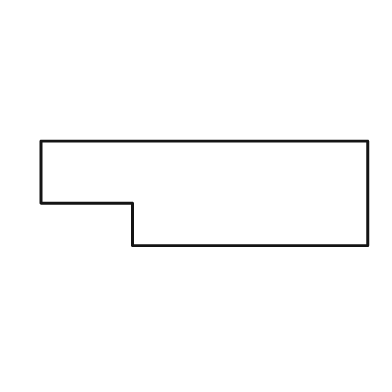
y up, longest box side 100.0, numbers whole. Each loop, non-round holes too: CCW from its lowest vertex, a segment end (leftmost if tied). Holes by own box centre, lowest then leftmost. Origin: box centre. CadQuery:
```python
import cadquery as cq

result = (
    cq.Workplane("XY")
    .moveTo(-22.0, -16.0)
    .lineTo(50.0, -16.0)
    .lineTo(50.0, 16.0)
    .lineTo(-50.0, 16.0)
    .lineTo(-50.0, -3.0)
    .lineTo(-22.0, -3.0)
    .close()
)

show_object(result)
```